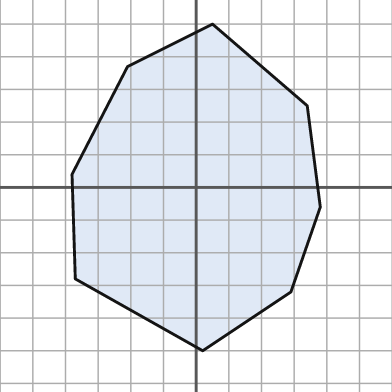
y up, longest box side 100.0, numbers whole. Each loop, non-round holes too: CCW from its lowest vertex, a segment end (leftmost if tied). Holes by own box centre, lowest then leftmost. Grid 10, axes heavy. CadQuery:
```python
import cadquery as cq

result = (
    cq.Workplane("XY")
    .moveTo(2.0, -50.0)
    .lineTo(29.0, -32.0)
    .lineTo(38.0, -6.0)
    .lineTo(34.0, 25.0)
    .lineTo(5.0, 50.0)
    .lineTo(-21.0, 37.0)
    .lineTo(-38.0, 4.0)
    .lineTo(-37.0, -28.0)
    .close()
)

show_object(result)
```